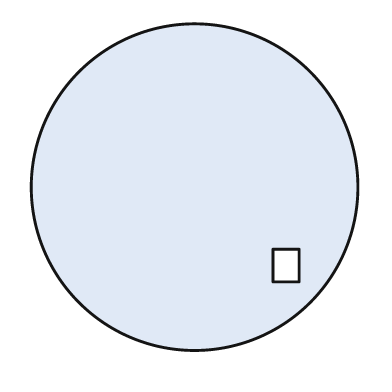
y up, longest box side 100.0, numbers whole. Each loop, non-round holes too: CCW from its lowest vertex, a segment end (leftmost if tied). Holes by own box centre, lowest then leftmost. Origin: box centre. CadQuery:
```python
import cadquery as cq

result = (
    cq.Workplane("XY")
    .moveTo(0.0, 0.0)
    .circle(50.0)
    .moveTo(24.0, -29.0)
    .lineTo(32.0, -29.0)
    .lineTo(32.0, -19.0)
    .lineTo(24.0, -19.0)
    .close()
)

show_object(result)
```